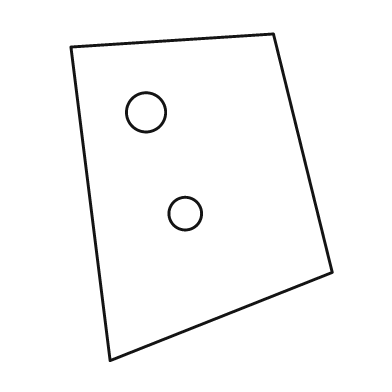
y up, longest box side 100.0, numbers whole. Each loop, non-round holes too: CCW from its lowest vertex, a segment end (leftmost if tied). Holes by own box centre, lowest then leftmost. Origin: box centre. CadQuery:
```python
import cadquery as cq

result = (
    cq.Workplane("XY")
    .moveTo(-28.0, -50.0)
    .lineTo(40.0, -23.0)
    .lineTo(22.0, 50.0)
    .lineTo(-40.0, 46.0)
    .close()
    .moveTo(-5.0, -5.0)
    .circle(5.0)
    .moveTo(-17.0, 26.0)
    .circle(6.0)
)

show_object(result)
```